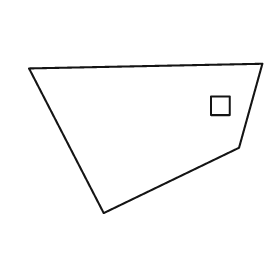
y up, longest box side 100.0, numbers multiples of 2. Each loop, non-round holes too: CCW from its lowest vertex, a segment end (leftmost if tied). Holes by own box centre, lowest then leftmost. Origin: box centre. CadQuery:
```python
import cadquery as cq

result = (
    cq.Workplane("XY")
    .moveTo(-18.0, -32.0)
    .lineTo(40.0, -4.0)
    .lineTo(50.0, 32.0)
    .lineTo(-50.0, 30.0)
    .close()
    .moveTo(28.0, 10.0)
    .lineTo(36.0, 10.0)
    .lineTo(36.0, 18.0)
    .lineTo(28.0, 18.0)
    .close()
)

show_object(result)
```